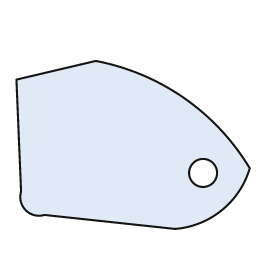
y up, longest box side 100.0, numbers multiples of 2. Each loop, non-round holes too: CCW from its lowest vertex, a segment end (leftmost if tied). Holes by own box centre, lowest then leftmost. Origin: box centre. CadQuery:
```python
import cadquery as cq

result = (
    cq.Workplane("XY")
    .moveTo(18.0, -36.0)
    .threePointArc((38.0, -28.0), (50.0, -10.0))
    .threePointArc((22.0, 20.0), (-16.0, 36.0))
    .lineTo(-50.0, 28.0)
    .lineTo(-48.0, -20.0)
    .threePointArc((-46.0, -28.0), (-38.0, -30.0))
    .close()
    .moveTo(30.0, -12.0)
    .circle(6.0)
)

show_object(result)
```